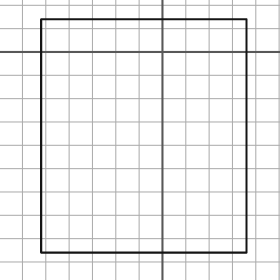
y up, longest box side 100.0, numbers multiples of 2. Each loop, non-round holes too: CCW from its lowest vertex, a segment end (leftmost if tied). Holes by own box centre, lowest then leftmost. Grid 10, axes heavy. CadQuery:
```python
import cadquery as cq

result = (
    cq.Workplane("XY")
    .moveTo(-52.0, -86.0)
    .lineTo(36.0, -86.0)
    .lineTo(36.0, 14.0)
    .lineTo(-52.0, 14.0)
    .close()
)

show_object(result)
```